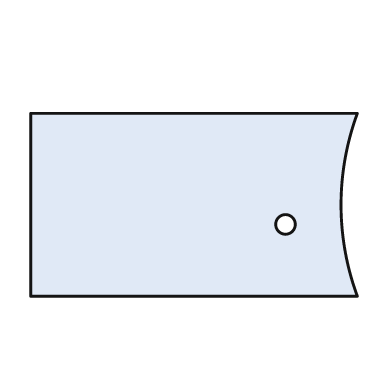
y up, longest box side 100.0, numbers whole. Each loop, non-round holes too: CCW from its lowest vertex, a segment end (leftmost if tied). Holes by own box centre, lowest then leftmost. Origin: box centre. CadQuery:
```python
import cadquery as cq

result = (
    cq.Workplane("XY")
    .moveTo(-50.0, -28.0)
    .lineTo(50.0, -28.0)
    .threePointArc((45.0, 0.0), (50.0, 28.0))
    .lineTo(-50.0, 28.0)
    .close()
    .moveTo(28.0, -6.0)
    .circle(3.0)
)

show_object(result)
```